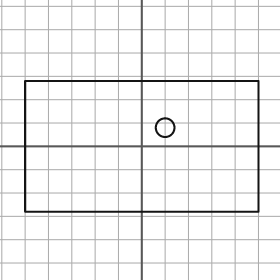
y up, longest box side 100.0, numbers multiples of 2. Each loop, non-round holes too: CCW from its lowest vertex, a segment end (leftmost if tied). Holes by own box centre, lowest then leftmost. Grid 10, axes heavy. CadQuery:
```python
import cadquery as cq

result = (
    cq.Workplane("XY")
    .moveTo(-50.0, -28.0)
    .lineTo(50.0, -28.0)
    .lineTo(50.0, 28.0)
    .lineTo(-50.0, 28.0)
    .close()
    .moveTo(10.0, 8.0)
    .circle(4.0)
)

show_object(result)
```